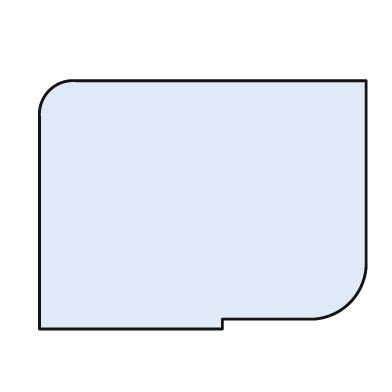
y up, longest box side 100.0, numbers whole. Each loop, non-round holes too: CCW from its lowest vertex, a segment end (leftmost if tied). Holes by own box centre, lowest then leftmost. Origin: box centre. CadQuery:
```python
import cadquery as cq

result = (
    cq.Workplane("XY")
    .moveTo(-50.0, -38.0)
    .lineTo(6.0, -38.0)
    .lineTo(6.0, -35.0)
    .lineTo(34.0, -35.0)
    .threePointArc((45.0, -30.0), (50.0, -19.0))
    .lineTo(50.0, 38.0)
    .lineTo(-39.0, 38.0)
    .threePointArc((-47.0, 35.0), (-50.0, 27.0))
    .close()
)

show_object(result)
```